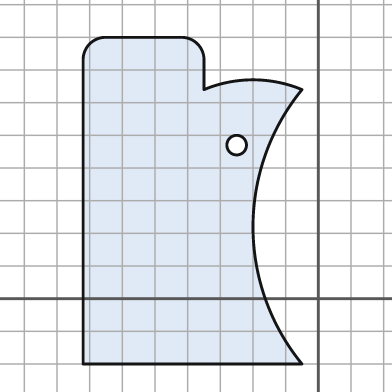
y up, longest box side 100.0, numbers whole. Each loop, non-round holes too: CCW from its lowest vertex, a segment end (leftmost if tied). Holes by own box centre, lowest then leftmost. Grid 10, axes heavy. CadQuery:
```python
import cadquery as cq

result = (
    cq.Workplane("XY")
    .moveTo(-72.0, -20.0)
    .lineTo(-5.0, -20.0)
    .threePointArc((-20.0, 22.0), (-5.0, 64.0))
    .threePointArc((-20.0, 67.0), (-35.0, 64.0))
    .lineTo(-35.0, 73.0)
    .threePointArc((-37.0, 78.0), (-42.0, 80.0))
    .lineTo(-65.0, 80.0)
    .threePointArc((-70.0, 78.0), (-72.0, 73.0))
    .close()
    .moveTo(-25.0, 47.0)
    .circle(3.0)
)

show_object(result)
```